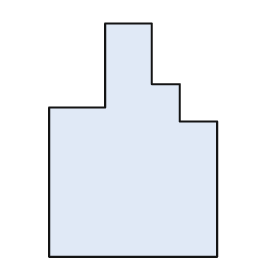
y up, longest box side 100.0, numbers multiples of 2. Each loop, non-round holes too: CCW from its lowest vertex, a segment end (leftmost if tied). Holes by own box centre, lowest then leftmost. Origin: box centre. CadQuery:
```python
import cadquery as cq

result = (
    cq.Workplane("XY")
    .moveTo(-36.0, -50.0)
    .lineTo(36.0, -50.0)
    .lineTo(36.0, 8.0)
    .lineTo(20.0, 8.0)
    .lineTo(20.0, 24.0)
    .lineTo(8.0, 24.0)
    .lineTo(8.0, 50.0)
    .lineTo(-12.0, 50.0)
    .lineTo(-12.0, 14.0)
    .lineTo(-36.0, 14.0)
    .close()
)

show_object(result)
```